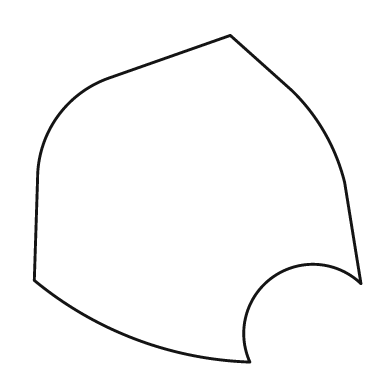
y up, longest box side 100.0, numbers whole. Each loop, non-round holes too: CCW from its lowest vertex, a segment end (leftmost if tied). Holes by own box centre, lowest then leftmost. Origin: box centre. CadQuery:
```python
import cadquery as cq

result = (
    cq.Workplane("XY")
    .moveTo(16.0, -50.0)
    .threePointArc((23.0, -24.0), (50.0, -26.0))
    .lineTo(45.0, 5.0)
    .threePointArc((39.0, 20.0), (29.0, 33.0))
    .lineTo(10.0, 50.0)
    .lineTo(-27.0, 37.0)
    .threePointArc((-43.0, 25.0), (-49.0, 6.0))
    .lineTo(-50.0, -25.0)
    .threePointArc((-19.0, -43.0), (16.0, -50.0))
    .close()
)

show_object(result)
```